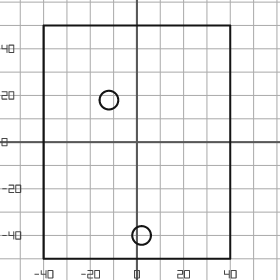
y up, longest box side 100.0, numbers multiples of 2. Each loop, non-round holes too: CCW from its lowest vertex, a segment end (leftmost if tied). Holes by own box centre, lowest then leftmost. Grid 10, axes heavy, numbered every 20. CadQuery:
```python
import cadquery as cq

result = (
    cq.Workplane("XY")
    .moveTo(-40.0, -50.0)
    .lineTo(40.0, -50.0)
    .lineTo(40.0, 50.0)
    .lineTo(-40.0, 50.0)
    .close()
    .moveTo(2.0, -40.0)
    .circle(4.0)
    .moveTo(-12.0, 18.0)
    .circle(4.0)
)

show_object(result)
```